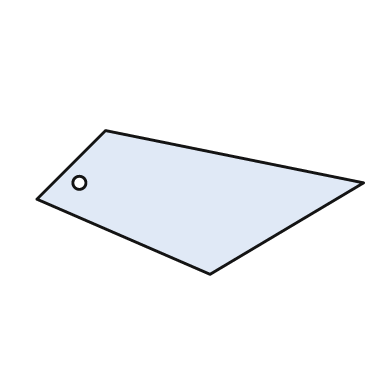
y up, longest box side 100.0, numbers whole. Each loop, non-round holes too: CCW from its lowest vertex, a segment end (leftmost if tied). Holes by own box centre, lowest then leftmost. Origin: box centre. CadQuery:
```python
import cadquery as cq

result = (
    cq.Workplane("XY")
    .moveTo(3.0, -22.0)
    .lineTo(50.0, 6.0)
    .lineTo(-29.0, 22.0)
    .lineTo(-50.0, 1.0)
    .close()
    .moveTo(-37.0, 6.0)
    .circle(2.0)
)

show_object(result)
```